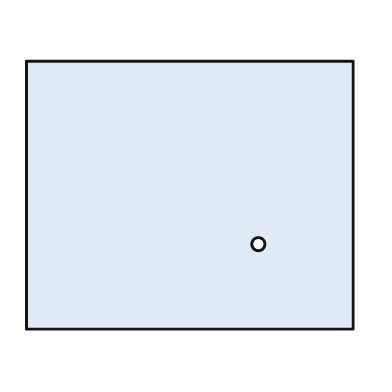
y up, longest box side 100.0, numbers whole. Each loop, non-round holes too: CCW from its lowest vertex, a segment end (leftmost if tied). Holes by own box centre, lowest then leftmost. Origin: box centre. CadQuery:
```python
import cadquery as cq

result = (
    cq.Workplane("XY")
    .moveTo(-50.0, -41.0)
    .lineTo(50.0, -41.0)
    .lineTo(50.0, 41.0)
    .lineTo(-50.0, 41.0)
    .close()
    .moveTo(21.0, -15.0)
    .circle(2.0)
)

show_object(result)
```